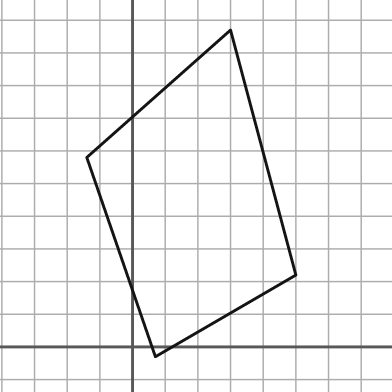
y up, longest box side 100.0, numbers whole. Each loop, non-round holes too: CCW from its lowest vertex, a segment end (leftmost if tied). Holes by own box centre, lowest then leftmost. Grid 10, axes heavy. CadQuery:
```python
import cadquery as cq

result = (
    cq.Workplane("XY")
    .moveTo(7.0, -3.0)
    .lineTo(50.0, 22.0)
    .lineTo(30.0, 97.0)
    .lineTo(-14.0, 58.0)
    .close()
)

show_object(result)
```